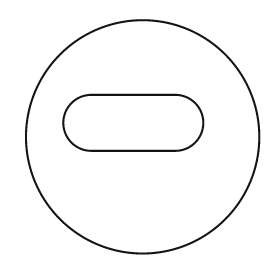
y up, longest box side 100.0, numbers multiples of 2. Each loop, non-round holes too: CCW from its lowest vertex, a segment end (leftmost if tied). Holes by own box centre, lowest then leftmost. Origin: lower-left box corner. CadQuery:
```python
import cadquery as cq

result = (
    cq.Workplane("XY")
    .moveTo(50.0, 50.0)
    .circle(50.0)
    .moveTo(28.0, 44.0)
    .lineTo(64.0, 44.0)
    .threePointArc((76.0, 56.0), (64.0, 68.0))
    .lineTo(28.0, 68.0)
    .threePointArc((16.0, 56.0), (28.0, 44.0))
    .close()
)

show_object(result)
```